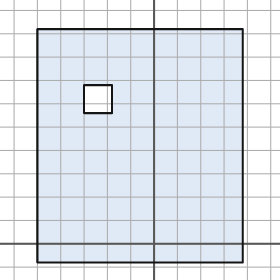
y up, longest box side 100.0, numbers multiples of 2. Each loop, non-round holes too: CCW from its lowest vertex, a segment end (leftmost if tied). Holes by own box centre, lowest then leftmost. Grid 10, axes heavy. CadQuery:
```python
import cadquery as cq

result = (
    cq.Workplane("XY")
    .moveTo(-50.0, -8.0)
    .lineTo(38.0, -8.0)
    .lineTo(38.0, 92.0)
    .lineTo(-50.0, 92.0)
    .close()
    .moveTo(-30.0, 56.0)
    .lineTo(-18.0, 56.0)
    .lineTo(-18.0, 68.0)
    .lineTo(-30.0, 68.0)
    .close()
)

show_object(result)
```